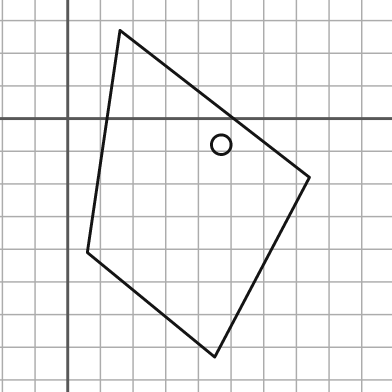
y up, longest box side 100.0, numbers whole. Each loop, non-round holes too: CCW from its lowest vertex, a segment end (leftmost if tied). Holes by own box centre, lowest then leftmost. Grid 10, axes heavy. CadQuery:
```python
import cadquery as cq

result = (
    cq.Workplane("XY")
    .moveTo(45.0, -73.0)
    .lineTo(74.0, -18.0)
    .lineTo(16.0, 27.0)
    .lineTo(6.0, -41.0)
    .close()
    .moveTo(47.0, -8.0)
    .circle(3.0)
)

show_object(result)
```